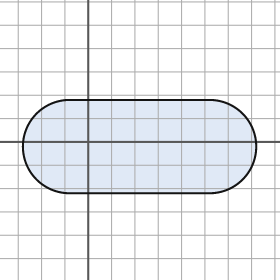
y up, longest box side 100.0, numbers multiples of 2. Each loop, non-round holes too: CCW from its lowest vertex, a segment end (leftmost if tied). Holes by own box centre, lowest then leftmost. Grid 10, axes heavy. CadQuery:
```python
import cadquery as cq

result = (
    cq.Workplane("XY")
    .moveTo(-8.0, -22.0)
    .lineTo(52.0, -22.0)
    .threePointArc((72.0, -2.0), (52.0, 18.0))
    .lineTo(-8.0, 18.0)
    .threePointArc((-28.0, -2.0), (-8.0, -22.0))
    .close()
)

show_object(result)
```